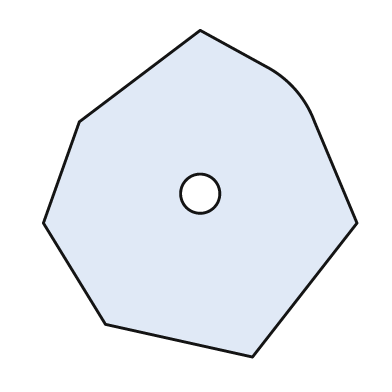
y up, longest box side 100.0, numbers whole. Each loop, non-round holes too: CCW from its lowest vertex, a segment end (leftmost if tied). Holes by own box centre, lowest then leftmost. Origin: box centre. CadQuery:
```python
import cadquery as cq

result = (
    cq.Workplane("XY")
    .moveTo(16.0, -50.0)
    .lineTo(48.0, -9.0)
    .lineTo(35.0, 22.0)
    .threePointArc((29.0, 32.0), (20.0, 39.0))
    .lineTo(0.0, 50.0)
    .lineTo(-37.0, 22.0)
    .lineTo(-48.0, -9.0)
    .lineTo(-29.0, -40.0)
    .close()
    .moveTo(0.0, 0.0)
    .circle(6.0)
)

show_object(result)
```